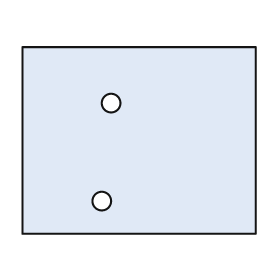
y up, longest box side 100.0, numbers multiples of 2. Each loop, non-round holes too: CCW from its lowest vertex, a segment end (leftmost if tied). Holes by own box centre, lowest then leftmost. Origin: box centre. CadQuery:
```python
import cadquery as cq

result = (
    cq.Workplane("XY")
    .moveTo(-50.0, -40.0)
    .lineTo(50.0, -40.0)
    .lineTo(50.0, 40.0)
    .lineTo(-50.0, 40.0)
    .close()
    .moveTo(-16.0, -26.0)
    .circle(4.0)
    .moveTo(-12.0, 16.0)
    .circle(4.0)
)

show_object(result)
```